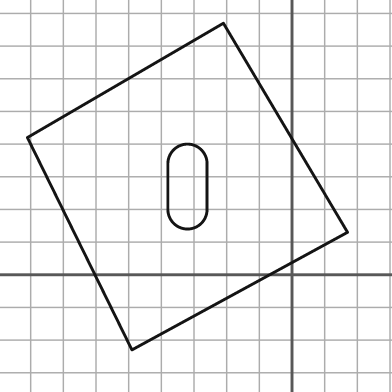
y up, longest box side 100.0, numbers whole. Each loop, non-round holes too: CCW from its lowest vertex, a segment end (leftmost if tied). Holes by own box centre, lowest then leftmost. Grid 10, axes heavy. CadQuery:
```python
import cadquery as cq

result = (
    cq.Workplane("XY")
    .moveTo(-49.0, -23.0)
    .lineTo(17.0, 13.0)
    .lineTo(-21.0, 77.0)
    .lineTo(-81.0, 42.0)
    .close()
    .moveTo(-38.0, 20.0)
    .threePointArc((-32.0, 14.0), (-26.0, 20.0))
    .lineTo(-26.0, 34.0)
    .threePointArc((-32.0, 40.0), (-38.0, 34.0))
    .close()
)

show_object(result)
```